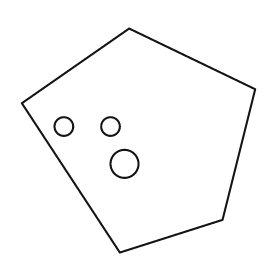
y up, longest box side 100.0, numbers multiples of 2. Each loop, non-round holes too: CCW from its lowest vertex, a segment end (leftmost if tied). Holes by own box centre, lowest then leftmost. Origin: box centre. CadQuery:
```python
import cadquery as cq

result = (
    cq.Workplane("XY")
    .moveTo(-8.0, -48.0)
    .lineTo(36.0, -34.0)
    .lineTo(50.0, 22.0)
    .lineTo(-4.0, 48.0)
    .lineTo(-50.0, 16.0)
    .close()
    .moveTo(-6.0, -10.0)
    .circle(6.0)
    .moveTo(-32.0, 6.0)
    .circle(4.0)
    .moveTo(-12.0, 6.0)
    .circle(4.0)
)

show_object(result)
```